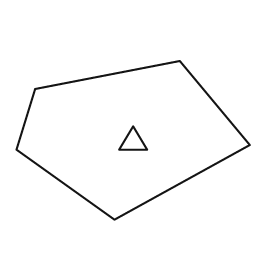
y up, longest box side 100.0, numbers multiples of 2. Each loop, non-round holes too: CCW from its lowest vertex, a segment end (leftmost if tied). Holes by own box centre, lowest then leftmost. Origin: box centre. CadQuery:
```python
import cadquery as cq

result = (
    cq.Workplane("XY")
    .moveTo(-8.0, -34.0)
    .lineTo(50.0, -2.0)
    .lineTo(20.0, 34.0)
    .lineTo(-42.0, 22.0)
    .lineTo(-50.0, -4.0)
    .close()
    .moveTo(-6.0, -4.0)
    .lineTo(6.0, -4.0)
    .lineTo(0.0, 6.0)
    .close()
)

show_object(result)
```